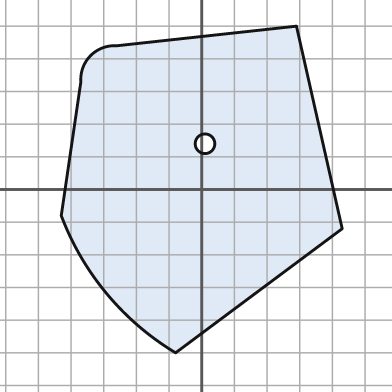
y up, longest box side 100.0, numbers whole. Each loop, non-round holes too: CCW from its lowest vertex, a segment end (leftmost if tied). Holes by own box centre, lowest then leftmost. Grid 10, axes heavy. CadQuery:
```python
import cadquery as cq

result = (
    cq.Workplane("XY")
    .moveTo(-8.0, -50.0)
    .lineTo(43.0, -12.0)
    .lineTo(29.0, 50.0)
    .lineTo(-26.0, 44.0)
    .threePointArc((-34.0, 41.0), (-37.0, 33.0))
    .lineTo(-43.0, -8.0)
    .threePointArc((-29.0, -32.0), (-8.0, -50.0))
    .close()
    .moveTo(1.0, 14.0)
    .circle(3.0)
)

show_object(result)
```